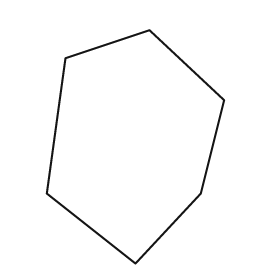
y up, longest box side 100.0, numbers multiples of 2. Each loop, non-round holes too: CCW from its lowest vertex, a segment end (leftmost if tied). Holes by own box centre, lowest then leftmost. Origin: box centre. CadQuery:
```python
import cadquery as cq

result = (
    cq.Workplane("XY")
    .moveTo(0.0, -50.0)
    .lineTo(28.0, -20.0)
    .lineTo(38.0, 20.0)
    .lineTo(6.0, 50.0)
    .lineTo(-30.0, 38.0)
    .lineTo(-38.0, -20.0)
    .close()
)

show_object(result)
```